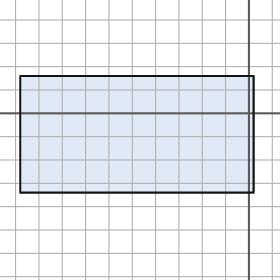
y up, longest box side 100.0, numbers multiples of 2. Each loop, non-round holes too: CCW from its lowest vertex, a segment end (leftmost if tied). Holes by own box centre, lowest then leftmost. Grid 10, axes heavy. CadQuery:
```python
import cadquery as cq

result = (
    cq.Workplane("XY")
    .moveTo(-98.0, -34.0)
    .lineTo(2.0, -34.0)
    .lineTo(2.0, 16.0)
    .lineTo(-98.0, 16.0)
    .close()
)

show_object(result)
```